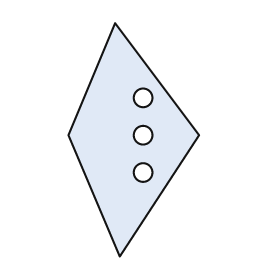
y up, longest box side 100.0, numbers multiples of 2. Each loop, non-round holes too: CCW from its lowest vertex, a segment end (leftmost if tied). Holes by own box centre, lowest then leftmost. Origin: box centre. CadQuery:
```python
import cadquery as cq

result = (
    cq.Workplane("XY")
    .moveTo(-6.0, -50.0)
    .lineTo(28.0, 2.0)
    .lineTo(-8.0, 50.0)
    .lineTo(-28.0, 2.0)
    .close()
    .moveTo(4.0, -14.0)
    .circle(4.0)
    .moveTo(4.0, 2.0)
    .circle(4.0)
    .moveTo(4.0, 18.0)
    .circle(4.0)
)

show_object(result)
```